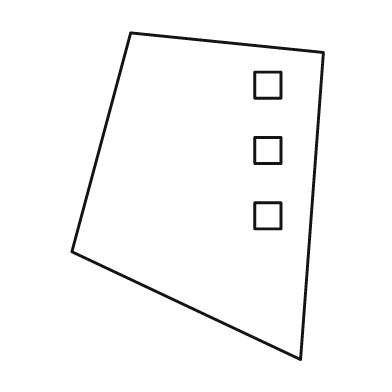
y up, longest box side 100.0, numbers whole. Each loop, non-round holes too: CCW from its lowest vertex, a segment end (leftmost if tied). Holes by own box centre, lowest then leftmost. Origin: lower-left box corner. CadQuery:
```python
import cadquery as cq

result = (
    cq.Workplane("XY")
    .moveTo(70.0, 0.0)
    .lineTo(77.0, 94.0)
    .lineTo(18.0, 100.0)
    .lineTo(0.0, 33.0)
    .close()
    .moveTo(56.0, 40.0)
    .lineTo(64.0, 40.0)
    .lineTo(64.0, 48.0)
    .lineTo(56.0, 48.0)
    .close()
    .moveTo(56.0, 60.0)
    .lineTo(64.0, 60.0)
    .lineTo(64.0, 68.0)
    .lineTo(56.0, 68.0)
    .close()
    .moveTo(56.0, 80.0)
    .lineTo(64.0, 80.0)
    .lineTo(64.0, 88.0)
    .lineTo(56.0, 88.0)
    .close()
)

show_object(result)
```